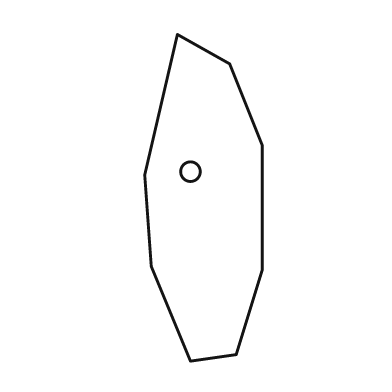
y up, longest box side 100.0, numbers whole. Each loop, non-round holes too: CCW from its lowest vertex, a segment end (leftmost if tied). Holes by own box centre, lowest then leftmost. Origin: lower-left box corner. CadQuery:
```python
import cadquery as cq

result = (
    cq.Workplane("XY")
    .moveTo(14.0, 0.0)
    .lineTo(28.0, 2.0)
    .lineTo(36.0, 28.0)
    .lineTo(36.0, 66.0)
    .lineTo(26.0, 91.0)
    .lineTo(10.0, 100.0)
    .lineTo(0.0, 57.0)
    .lineTo(2.0, 29.0)
    .close()
    .moveTo(14.0, 58.0)
    .circle(3.0)
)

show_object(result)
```